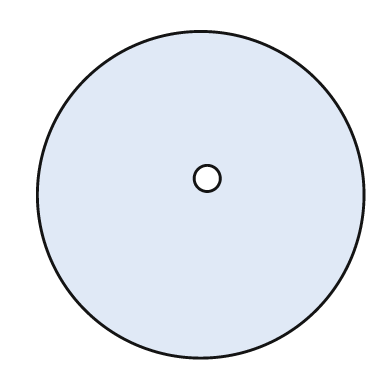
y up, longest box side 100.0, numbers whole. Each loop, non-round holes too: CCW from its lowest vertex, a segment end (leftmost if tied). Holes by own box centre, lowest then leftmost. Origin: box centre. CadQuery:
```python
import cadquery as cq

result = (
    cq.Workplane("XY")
    .moveTo(0.0, 0.0)
    .circle(50.0)
    .moveTo(2.0, 5.0)
    .circle(4.0)
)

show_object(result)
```